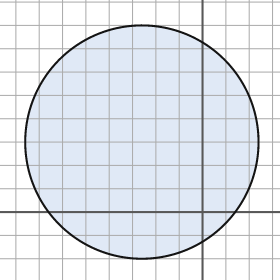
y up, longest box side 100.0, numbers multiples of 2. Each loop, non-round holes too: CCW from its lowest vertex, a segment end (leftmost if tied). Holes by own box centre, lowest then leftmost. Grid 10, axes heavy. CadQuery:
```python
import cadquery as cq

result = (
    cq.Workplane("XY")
    .moveTo(-26.0, 30.0)
    .circle(50.0)
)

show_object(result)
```